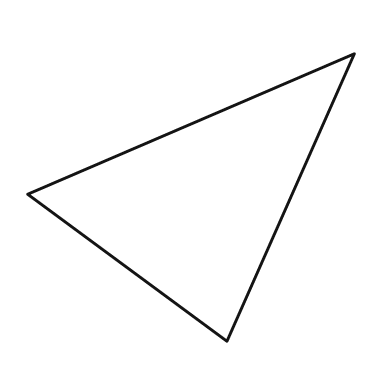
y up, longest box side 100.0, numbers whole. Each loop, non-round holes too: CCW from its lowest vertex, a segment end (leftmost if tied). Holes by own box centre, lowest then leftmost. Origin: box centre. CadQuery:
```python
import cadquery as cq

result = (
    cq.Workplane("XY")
    .moveTo(11.0, -44.0)
    .lineTo(50.0, 44.0)
    .lineTo(-50.0, 1.0)
    .close()
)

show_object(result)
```